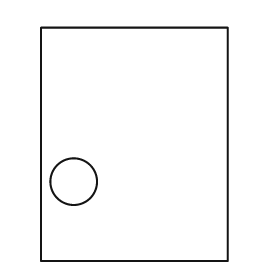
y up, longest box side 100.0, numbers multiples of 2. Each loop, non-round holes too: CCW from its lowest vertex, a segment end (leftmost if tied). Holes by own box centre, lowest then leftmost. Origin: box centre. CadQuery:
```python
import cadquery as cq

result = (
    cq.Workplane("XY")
    .moveTo(-40.0, -50.0)
    .lineTo(40.0, -50.0)
    .lineTo(40.0, 50.0)
    .lineTo(-40.0, 50.0)
    .close()
    .moveTo(-26.0, -16.0)
    .circle(10.0)
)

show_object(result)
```